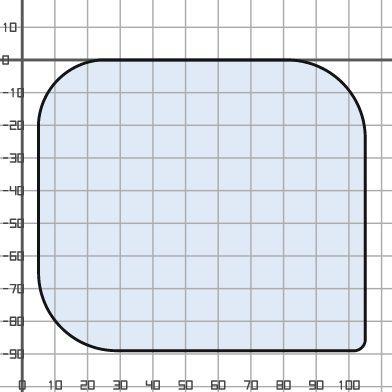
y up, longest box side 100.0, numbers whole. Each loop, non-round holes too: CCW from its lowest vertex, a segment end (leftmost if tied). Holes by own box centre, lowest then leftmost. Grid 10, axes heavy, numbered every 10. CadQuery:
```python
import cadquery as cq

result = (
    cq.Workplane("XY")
    .moveTo(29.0, -89.0)
    .lineTo(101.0, -89.0)
    .threePointArc((104.0, -88.0), (105.0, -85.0))
    .lineTo(105.0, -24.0)
    .threePointArc((98.0, -7.0), (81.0, 0.0))
    .lineTo(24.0, 0.0)
    .threePointArc((11.0, -6.0), (5.0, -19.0))
    .lineTo(5.0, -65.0)
    .threePointArc((12.0, -82.0), (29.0, -89.0))
    .close()
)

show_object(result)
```